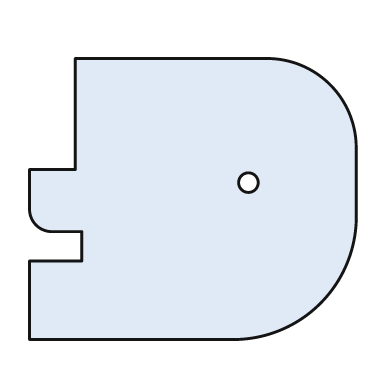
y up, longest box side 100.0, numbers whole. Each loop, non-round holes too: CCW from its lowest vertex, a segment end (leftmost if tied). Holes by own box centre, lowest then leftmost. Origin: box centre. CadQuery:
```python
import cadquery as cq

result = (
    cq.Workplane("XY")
    .moveTo(-50.0, -43.0)
    .lineTo(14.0, -43.0)
    .threePointArc((39.0, -32.0), (50.0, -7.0))
    .lineTo(50.0, 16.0)
    .threePointArc((42.0, 35.0), (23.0, 43.0))
    .lineTo(-36.0, 43.0)
    .lineTo(-36.0, 9.0)
    .lineTo(-50.0, 9.0)
    .lineTo(-50.0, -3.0)
    .threePointArc((-48.0, -8.0), (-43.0, -10.0))
    .lineTo(-34.0, -10.0)
    .lineTo(-34.0, -19.0)
    .lineTo(-50.0, -19.0)
    .close()
    .moveTo(17.0, 5.0)
    .circle(3.0)
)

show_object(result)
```